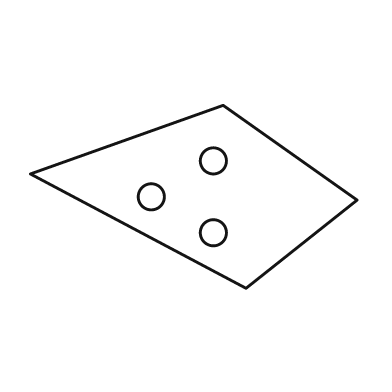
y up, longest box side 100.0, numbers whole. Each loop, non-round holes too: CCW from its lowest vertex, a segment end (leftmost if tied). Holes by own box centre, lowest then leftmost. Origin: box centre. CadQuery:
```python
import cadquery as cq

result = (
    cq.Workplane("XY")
    .moveTo(16.0, -28.0)
    .lineTo(50.0, -1.0)
    .lineTo(9.0, 28.0)
    .lineTo(-50.0, 7.0)
    .close()
    .moveTo(6.0, -11.0)
    .circle(4.0)
    .moveTo(-13.0, 0.0)
    .circle(4.0)
    .moveTo(6.0, 11.0)
    .circle(4.0)
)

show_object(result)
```